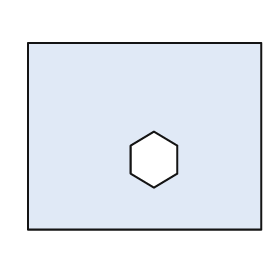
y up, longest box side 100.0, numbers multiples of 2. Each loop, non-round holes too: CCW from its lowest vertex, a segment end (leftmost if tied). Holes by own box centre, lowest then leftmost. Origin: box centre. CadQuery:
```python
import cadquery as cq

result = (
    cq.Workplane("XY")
    .moveTo(-50.0, -40.0)
    .lineTo(50.0, -40.0)
    .lineTo(50.0, 40.0)
    .lineTo(-50.0, 40.0)
    .close()
    .moveTo(4.0, -22.0)
    .lineTo(14.0, -16.0)
    .lineTo(14.0, -4.0)
    .lineTo(4.0, 2.0)
    .lineTo(-6.0, -4.0)
    .lineTo(-6.0, -16.0)
    .close()
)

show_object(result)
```